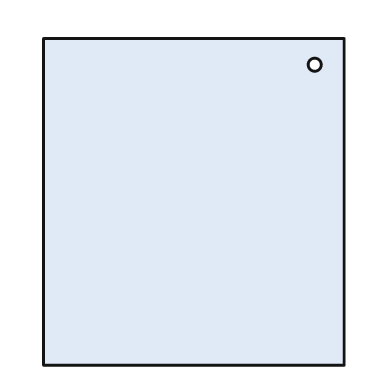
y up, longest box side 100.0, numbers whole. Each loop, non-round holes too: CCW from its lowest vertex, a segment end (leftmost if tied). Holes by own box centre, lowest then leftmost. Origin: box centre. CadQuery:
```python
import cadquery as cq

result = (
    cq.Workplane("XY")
    .moveTo(-46.0, -50.0)
    .lineTo(46.0, -50.0)
    .lineTo(46.0, 50.0)
    .lineTo(-46.0, 50.0)
    .close()
    .moveTo(37.0, 42.0)
    .circle(2.0)
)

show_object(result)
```